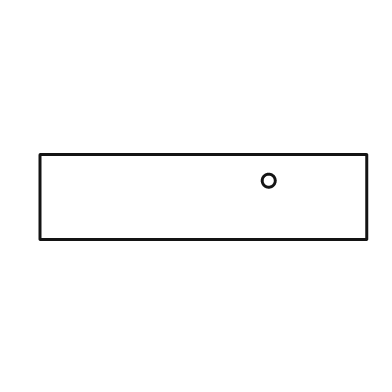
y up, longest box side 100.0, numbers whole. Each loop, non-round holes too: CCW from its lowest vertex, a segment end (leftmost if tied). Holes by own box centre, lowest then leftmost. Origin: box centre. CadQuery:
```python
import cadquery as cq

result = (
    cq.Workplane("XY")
    .moveTo(-50.0, -13.0)
    .lineTo(50.0, -13.0)
    .lineTo(50.0, 13.0)
    .lineTo(-50.0, 13.0)
    .close()
    .moveTo(20.0, 5.0)
    .circle(2.0)
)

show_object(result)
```